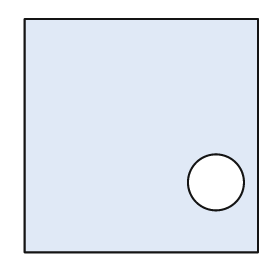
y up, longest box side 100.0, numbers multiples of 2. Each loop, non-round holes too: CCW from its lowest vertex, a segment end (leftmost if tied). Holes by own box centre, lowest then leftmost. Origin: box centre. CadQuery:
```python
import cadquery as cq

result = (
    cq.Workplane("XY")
    .moveTo(-50.0, -50.0)
    .lineTo(50.0, -50.0)
    .lineTo(50.0, 50.0)
    .lineTo(-50.0, 50.0)
    .close()
    .moveTo(32.0, -20.0)
    .circle(12.0)
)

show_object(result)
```